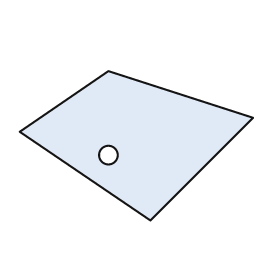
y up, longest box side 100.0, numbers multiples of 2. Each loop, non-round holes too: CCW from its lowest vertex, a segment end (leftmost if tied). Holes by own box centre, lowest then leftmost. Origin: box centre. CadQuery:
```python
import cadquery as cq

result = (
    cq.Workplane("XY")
    .moveTo(6.0, -32.0)
    .lineTo(50.0, 12.0)
    .lineTo(-12.0, 32.0)
    .lineTo(-50.0, 6.0)
    .close()
    .moveTo(-12.0, -4.0)
    .circle(4.0)
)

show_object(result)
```